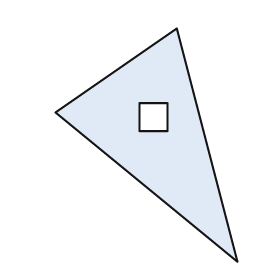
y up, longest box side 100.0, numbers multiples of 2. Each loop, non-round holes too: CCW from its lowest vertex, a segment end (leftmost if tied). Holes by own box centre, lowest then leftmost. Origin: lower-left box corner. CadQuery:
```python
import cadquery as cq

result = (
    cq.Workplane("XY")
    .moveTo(78.0, 0.0)
    .lineTo(52.0, 100.0)
    .lineTo(0.0, 64.0)
    .close()
    .moveTo(36.0, 56.0)
    .lineTo(48.0, 56.0)
    .lineTo(48.0, 68.0)
    .lineTo(36.0, 68.0)
    .close()
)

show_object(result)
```